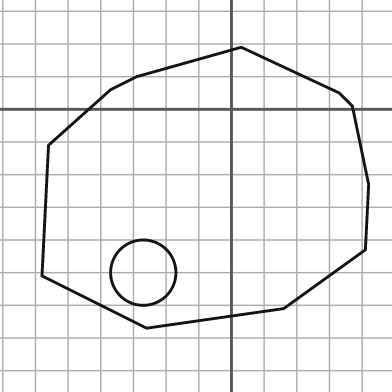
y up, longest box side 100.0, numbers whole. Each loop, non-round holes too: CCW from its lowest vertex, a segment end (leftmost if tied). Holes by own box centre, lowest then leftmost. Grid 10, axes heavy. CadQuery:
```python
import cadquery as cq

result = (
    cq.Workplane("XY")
    .moveTo(-26.0, -67.0)
    .lineTo(16.0, -61.0)
    .lineTo(41.0, -43.0)
    .lineTo(42.0, -23.0)
    .lineTo(37.0, 1.0)
    .lineTo(33.0, 5.0)
    .lineTo(3.0, 19.0)
    .lineTo(-29.0, 10.0)
    .lineTo(-37.0, 6.0)
    .lineTo(-56.0, -11.0)
    .lineTo(-58.0, -51.0)
    .close()
    .moveTo(-27.0, -50.0)
    .circle(10.0)
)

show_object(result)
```